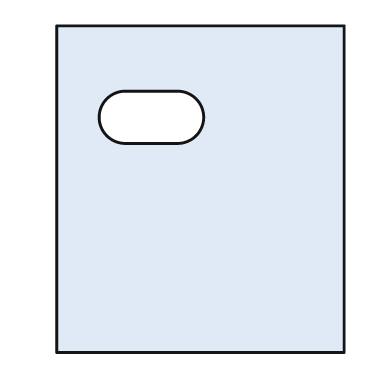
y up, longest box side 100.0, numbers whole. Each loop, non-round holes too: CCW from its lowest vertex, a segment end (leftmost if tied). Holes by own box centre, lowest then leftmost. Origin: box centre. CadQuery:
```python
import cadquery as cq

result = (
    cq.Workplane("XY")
    .moveTo(-44.0, -50.0)
    .lineTo(44.0, -50.0)
    .lineTo(44.0, 50.0)
    .lineTo(-44.0, 50.0)
    .close()
    .moveTo(-23.0, 14.0)
    .lineTo(-7.0, 14.0)
    .threePointArc((1.0, 22.0), (-7.0, 30.0))
    .lineTo(-23.0, 30.0)
    .threePointArc((-31.0, 22.0), (-23.0, 14.0))
    .close()
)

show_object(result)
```